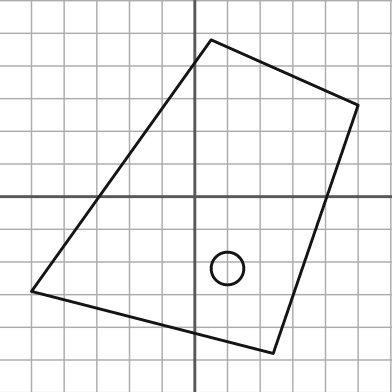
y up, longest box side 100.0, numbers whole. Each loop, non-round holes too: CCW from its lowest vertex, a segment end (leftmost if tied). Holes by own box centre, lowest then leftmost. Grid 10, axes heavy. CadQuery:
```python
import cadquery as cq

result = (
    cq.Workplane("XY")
    .moveTo(24.0, -48.0)
    .lineTo(50.0, 28.0)
    .lineTo(5.0, 48.0)
    .lineTo(-50.0, -29.0)
    .close()
    .moveTo(10.0, -22.0)
    .circle(5.0)
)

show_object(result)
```